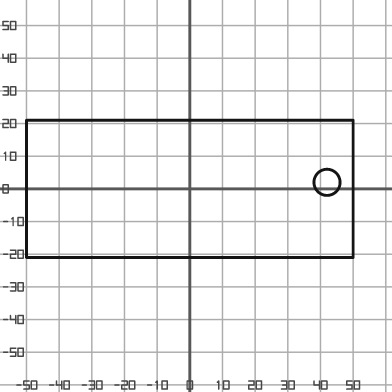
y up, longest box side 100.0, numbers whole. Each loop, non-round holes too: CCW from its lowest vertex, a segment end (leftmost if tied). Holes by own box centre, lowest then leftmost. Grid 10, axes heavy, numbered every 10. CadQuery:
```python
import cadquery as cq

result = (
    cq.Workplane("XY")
    .moveTo(-50.0, -21.0)
    .lineTo(50.0, -21.0)
    .lineTo(50.0, 21.0)
    .lineTo(-50.0, 21.0)
    .close()
    .moveTo(42.0, 2.0)
    .circle(4.0)
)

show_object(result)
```